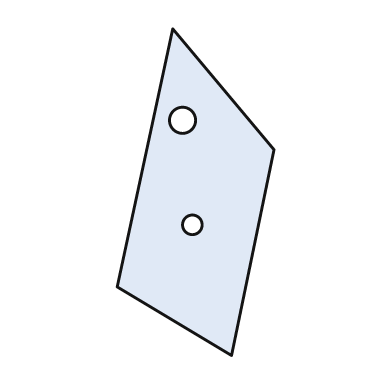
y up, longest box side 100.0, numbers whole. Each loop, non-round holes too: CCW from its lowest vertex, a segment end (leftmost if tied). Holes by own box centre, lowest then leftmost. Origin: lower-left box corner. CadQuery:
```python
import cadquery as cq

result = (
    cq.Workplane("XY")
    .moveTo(35.0, 0.0)
    .lineTo(48.0, 63.0)
    .lineTo(17.0, 100.0)
    .lineTo(0.0, 21.0)
    .close()
    .moveTo(23.0, 40.0)
    .circle(3.0)
    .moveTo(20.0, 72.0)
    .circle(4.0)
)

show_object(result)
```